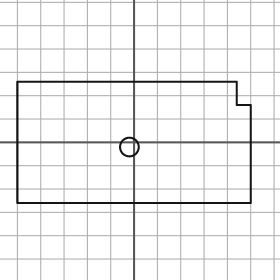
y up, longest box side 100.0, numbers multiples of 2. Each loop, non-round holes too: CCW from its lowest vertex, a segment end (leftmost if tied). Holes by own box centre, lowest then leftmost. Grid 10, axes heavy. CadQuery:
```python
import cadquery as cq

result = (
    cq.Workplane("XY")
    .moveTo(-50.0, -26.0)
    .lineTo(50.0, -26.0)
    .lineTo(50.0, 16.0)
    .lineTo(44.0, 16.0)
    .lineTo(44.0, 26.0)
    .lineTo(-50.0, 26.0)
    .close()
    .moveTo(-2.0, -2.0)
    .circle(4.0)
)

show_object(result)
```